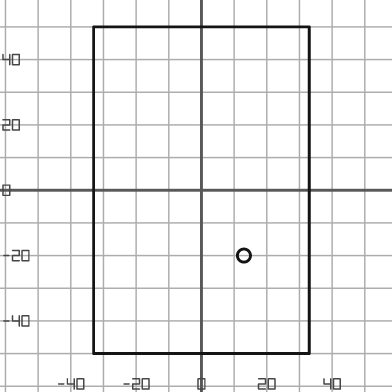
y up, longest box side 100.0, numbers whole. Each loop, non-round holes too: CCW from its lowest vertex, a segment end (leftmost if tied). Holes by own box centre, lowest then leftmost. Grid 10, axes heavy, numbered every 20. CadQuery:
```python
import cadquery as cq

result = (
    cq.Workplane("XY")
    .moveTo(-33.0, -50.0)
    .lineTo(33.0, -50.0)
    .lineTo(33.0, 50.0)
    .lineTo(-33.0, 50.0)
    .close()
    .moveTo(13.0, -20.0)
    .circle(2.0)
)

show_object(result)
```